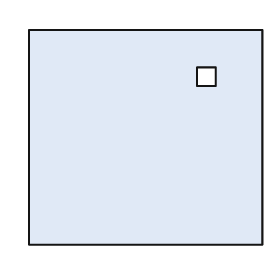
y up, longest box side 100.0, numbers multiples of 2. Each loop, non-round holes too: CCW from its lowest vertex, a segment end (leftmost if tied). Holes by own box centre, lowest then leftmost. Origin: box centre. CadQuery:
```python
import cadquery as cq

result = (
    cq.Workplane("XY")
    .moveTo(-50.0, -46.0)
    .lineTo(50.0, -46.0)
    .lineTo(50.0, 46.0)
    .lineTo(-50.0, 46.0)
    .close()
    .moveTo(22.0, 22.0)
    .lineTo(30.0, 22.0)
    .lineTo(30.0, 30.0)
    .lineTo(22.0, 30.0)
    .close()
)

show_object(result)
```